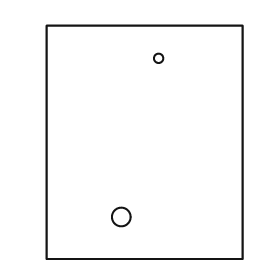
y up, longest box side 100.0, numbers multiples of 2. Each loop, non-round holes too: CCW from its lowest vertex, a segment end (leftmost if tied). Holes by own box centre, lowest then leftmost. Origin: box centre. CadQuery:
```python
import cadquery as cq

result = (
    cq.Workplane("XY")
    .moveTo(-42.0, -50.0)
    .lineTo(42.0, -50.0)
    .lineTo(42.0, 50.0)
    .lineTo(-42.0, 50.0)
    .close()
    .moveTo(-10.0, -32.0)
    .circle(4.0)
    .moveTo(6.0, 36.0)
    .circle(2.0)
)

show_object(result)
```